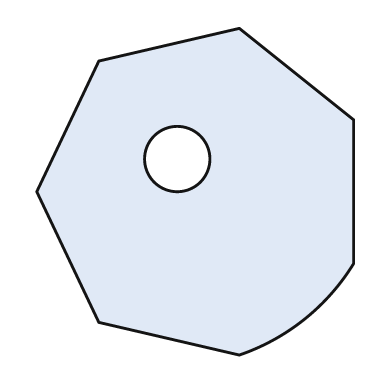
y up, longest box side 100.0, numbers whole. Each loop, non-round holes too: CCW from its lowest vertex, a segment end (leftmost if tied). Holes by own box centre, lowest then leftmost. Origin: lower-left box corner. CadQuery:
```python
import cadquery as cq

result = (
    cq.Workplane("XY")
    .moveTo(62.0, 0.0)
    .threePointArc((82.0, 11.0), (97.0, 28.0))
    .lineTo(97.0, 72.0)
    .lineTo(62.0, 100.0)
    .lineTo(19.0, 90.0)
    .lineTo(0.0, 50.0)
    .lineTo(19.0, 10.0)
    .close()
    .moveTo(43.0, 60.0)
    .circle(10.0)
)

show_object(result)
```